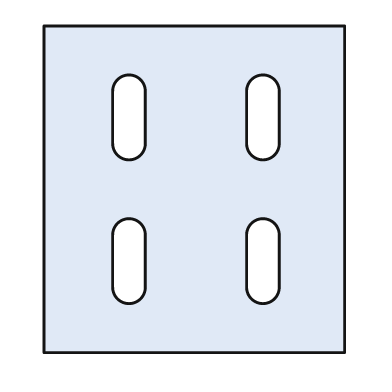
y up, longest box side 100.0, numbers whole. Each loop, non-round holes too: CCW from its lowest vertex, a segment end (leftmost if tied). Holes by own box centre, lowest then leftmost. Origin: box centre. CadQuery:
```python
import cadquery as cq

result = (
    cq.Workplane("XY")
    .moveTo(-46.0, -50.0)
    .lineTo(46.0, -50.0)
    .lineTo(46.0, 50.0)
    .lineTo(-46.0, 50.0)
    .close()
    .moveTo(-25.0, -30.0)
    .threePointArc((-20.0, -35.0), (-15.0, -30.0))
    .lineTo(-15.0, -14.0)
    .threePointArc((-20.0, -9.0), (-25.0, -14.0))
    .close()
    .moveTo(16.0, -30.0)
    .threePointArc((21.0, -35.0), (26.0, -30.0))
    .lineTo(26.0, -14.0)
    .threePointArc((21.0, -9.0), (16.0, -14.0))
    .close()
    .moveTo(-25.0, 14.0)
    .threePointArc((-20.0, 9.0), (-15.0, 14.0))
    .lineTo(-15.0, 30.0)
    .threePointArc((-20.0, 35.0), (-25.0, 30.0))
    .close()
    .moveTo(16.0, 14.0)
    .threePointArc((21.0, 9.0), (26.0, 14.0))
    .lineTo(26.0, 30.0)
    .threePointArc((21.0, 35.0), (16.0, 30.0))
    .close()
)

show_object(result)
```